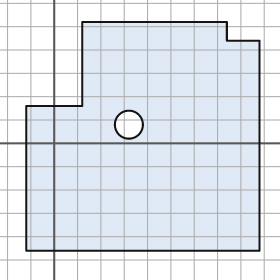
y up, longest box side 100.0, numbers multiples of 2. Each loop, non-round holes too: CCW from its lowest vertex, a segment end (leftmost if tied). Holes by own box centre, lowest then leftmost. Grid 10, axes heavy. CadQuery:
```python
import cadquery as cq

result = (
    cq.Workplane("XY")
    .moveTo(-12.0, -46.0)
    .lineTo(88.0, -46.0)
    .lineTo(88.0, 44.0)
    .lineTo(74.0, 44.0)
    .lineTo(74.0, 52.0)
    .lineTo(12.0, 52.0)
    .lineTo(12.0, 16.0)
    .lineTo(-12.0, 16.0)
    .close()
    .moveTo(32.0, 8.0)
    .circle(6.0)
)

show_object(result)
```